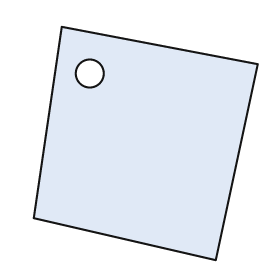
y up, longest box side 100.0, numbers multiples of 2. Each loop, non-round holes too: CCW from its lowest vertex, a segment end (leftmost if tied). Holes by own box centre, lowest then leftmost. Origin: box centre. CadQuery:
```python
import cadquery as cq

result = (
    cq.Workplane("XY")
    .moveTo(30.0, -50.0)
    .lineTo(48.0, 34.0)
    .lineTo(-36.0, 50.0)
    .lineTo(-48.0, -32.0)
    .close()
    .moveTo(-24.0, 30.0)
    .circle(6.0)
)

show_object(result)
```